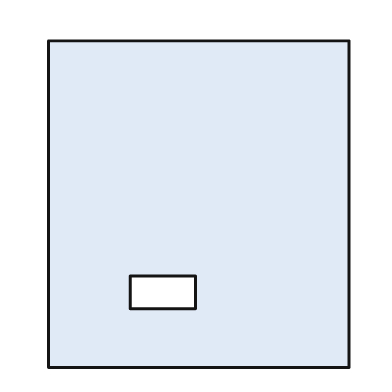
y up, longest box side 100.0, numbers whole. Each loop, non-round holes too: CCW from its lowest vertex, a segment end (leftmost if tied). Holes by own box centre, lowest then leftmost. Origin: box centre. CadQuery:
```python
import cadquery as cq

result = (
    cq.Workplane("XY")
    .moveTo(-46.0, -50.0)
    .lineTo(46.0, -50.0)
    .lineTo(46.0, 50.0)
    .lineTo(-46.0, 50.0)
    .close()
    .moveTo(-21.0, -32.0)
    .lineTo(-1.0, -32.0)
    .lineTo(-1.0, -22.0)
    .lineTo(-21.0, -22.0)
    .close()
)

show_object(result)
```